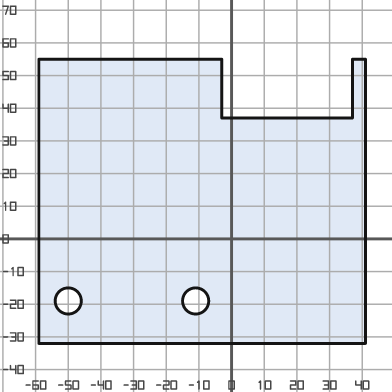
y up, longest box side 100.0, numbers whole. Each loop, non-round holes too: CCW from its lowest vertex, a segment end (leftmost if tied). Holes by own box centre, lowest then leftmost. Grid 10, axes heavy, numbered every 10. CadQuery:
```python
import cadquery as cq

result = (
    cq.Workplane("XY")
    .moveTo(-59.0, -32.0)
    .lineTo(41.0, -32.0)
    .lineTo(41.0, 55.0)
    .lineTo(37.0, 55.0)
    .lineTo(37.0, 37.0)
    .lineTo(-3.0, 37.0)
    .lineTo(-3.0, 55.0)
    .lineTo(-59.0, 55.0)
    .close()
    .moveTo(-50.0, -19.0)
    .circle(4.0)
    .moveTo(-11.0, -19.0)
    .circle(4.0)
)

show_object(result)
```